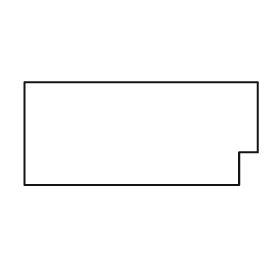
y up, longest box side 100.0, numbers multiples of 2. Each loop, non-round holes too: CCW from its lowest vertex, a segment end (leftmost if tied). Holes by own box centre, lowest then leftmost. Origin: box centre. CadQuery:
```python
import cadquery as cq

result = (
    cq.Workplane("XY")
    .moveTo(-50.0, -22.0)
    .lineTo(42.0, -22.0)
    .lineTo(42.0, -8.0)
    .lineTo(50.0, -8.0)
    .lineTo(50.0, 22.0)
    .lineTo(-50.0, 22.0)
    .close()
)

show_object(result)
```